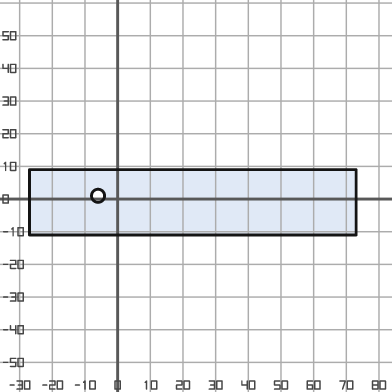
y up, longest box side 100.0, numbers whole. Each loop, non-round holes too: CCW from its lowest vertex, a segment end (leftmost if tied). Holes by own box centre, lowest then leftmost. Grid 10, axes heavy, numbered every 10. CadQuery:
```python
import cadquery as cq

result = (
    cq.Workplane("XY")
    .moveTo(-27.0, -11.0)
    .lineTo(73.0, -11.0)
    .lineTo(73.0, 9.0)
    .lineTo(-27.0, 9.0)
    .close()
    .moveTo(-6.0, 1.0)
    .circle(2.0)
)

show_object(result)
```